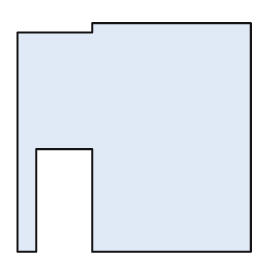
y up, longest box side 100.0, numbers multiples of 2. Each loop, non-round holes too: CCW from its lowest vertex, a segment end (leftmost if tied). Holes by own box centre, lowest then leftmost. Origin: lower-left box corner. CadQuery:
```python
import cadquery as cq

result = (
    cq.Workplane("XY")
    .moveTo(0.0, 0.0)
    .lineTo(8.0, 0.0)
    .lineTo(8.0, 44.0)
    .lineTo(32.0, 44.0)
    .lineTo(32.0, 0.0)
    .lineTo(100.0, 0.0)
    .lineTo(100.0, 98.0)
    .lineTo(32.0, 98.0)
    .lineTo(32.0, 94.0)
    .lineTo(0.0, 94.0)
    .close()
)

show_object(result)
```